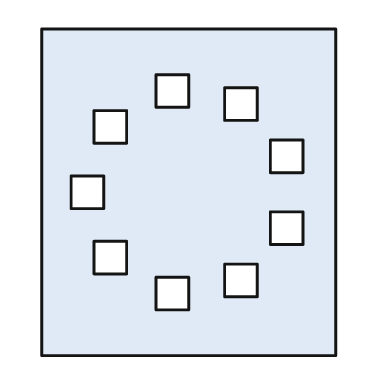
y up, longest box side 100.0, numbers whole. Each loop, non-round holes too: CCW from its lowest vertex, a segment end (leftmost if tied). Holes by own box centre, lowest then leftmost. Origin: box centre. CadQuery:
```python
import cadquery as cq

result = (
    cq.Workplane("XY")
    .moveTo(-45.0, -50.0)
    .lineTo(45.0, -50.0)
    .lineTo(45.0, 50.0)
    .lineTo(-45.0, 50.0)
    .close()
    .moveTo(-10.0, -36.0)
    .lineTo(0.0, -36.0)
    .lineTo(0.0, -26.0)
    .lineTo(-10.0, -26.0)
    .close()
    .moveTo(11.0, -32.0)
    .lineTo(21.0, -32.0)
    .lineTo(21.0, -22.0)
    .lineTo(11.0, -22.0)
    .close()
    .moveTo(-29.0, -25.0)
    .lineTo(-19.0, -25.0)
    .lineTo(-19.0, -15.0)
    .lineTo(-29.0, -15.0)
    .close()
    .moveTo(25.0, -16.0)
    .lineTo(35.0, -16.0)
    .lineTo(35.0, -6.0)
    .lineTo(25.0, -6.0)
    .close()
    .moveTo(-36.0, -5.0)
    .lineTo(-26.0, -5.0)
    .lineTo(-26.0, 5.0)
    .lineTo(-36.0, 5.0)
    .close()
    .moveTo(25.0, 6.0)
    .lineTo(35.0, 6.0)
    .lineTo(35.0, 16.0)
    .lineTo(25.0, 16.0)
    .close()
    .moveTo(-29.0, 15.0)
    .lineTo(-19.0, 15.0)
    .lineTo(-19.0, 25.0)
    .lineTo(-29.0, 25.0)
    .close()
    .moveTo(11.0, 22.0)
    .lineTo(21.0, 22.0)
    .lineTo(21.0, 32.0)
    .lineTo(11.0, 32.0)
    .close()
    .moveTo(-10.0, 26.0)
    .lineTo(0.0, 26.0)
    .lineTo(0.0, 36.0)
    .lineTo(-10.0, 36.0)
    .close()
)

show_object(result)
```